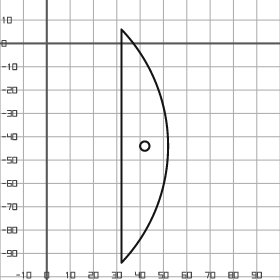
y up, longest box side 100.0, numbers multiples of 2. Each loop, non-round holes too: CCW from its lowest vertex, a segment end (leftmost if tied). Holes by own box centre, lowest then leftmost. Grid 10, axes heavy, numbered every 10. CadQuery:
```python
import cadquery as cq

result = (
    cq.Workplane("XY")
    .moveTo(32.0, -94.0)
    .threePointArc((52.0, -44.0), (32.0, 6.0))
    .close()
    .moveTo(42.0, -44.0)
    .circle(2.0)
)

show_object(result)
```